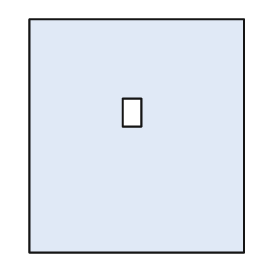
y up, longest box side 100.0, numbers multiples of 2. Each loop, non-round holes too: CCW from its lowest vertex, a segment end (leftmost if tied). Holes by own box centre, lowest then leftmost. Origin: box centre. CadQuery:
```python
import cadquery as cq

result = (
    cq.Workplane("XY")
    .moveTo(-46.0, -50.0)
    .lineTo(46.0, -50.0)
    .lineTo(46.0, 50.0)
    .lineTo(-46.0, 50.0)
    .close()
    .moveTo(-6.0, 4.0)
    .lineTo(2.0, 4.0)
    .lineTo(2.0, 16.0)
    .lineTo(-6.0, 16.0)
    .close()
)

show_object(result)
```